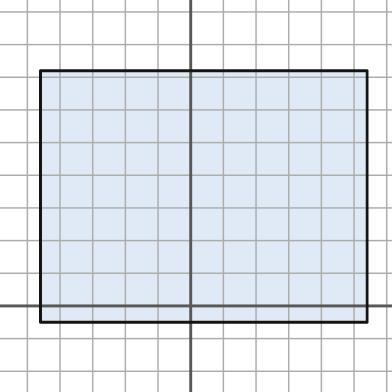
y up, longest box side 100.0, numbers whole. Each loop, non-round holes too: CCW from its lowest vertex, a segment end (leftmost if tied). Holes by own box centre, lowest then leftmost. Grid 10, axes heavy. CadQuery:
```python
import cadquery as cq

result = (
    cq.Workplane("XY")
    .moveTo(-46.0, -5.0)
    .lineTo(54.0, -5.0)
    .lineTo(54.0, 72.0)
    .lineTo(-46.0, 72.0)
    .close()
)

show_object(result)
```